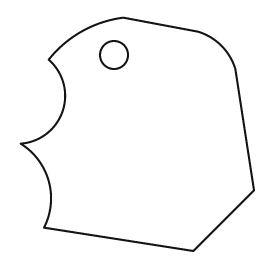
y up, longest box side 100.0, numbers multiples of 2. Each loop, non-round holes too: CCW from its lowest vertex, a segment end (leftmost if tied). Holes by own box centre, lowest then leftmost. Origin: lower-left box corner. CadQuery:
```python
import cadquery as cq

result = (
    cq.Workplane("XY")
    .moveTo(74.0, 0.0)
    .lineTo(100.0, 26.0)
    .lineTo(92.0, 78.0)
    .threePointArc((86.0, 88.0), (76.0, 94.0))
    .lineTo(44.0, 100.0)
    .threePointArc((26.0, 94.0), (12.0, 82.0))
    .threePointArc((18.0, 60.0), (0.0, 46.0))
    .threePointArc((12.0, 30.0), (10.0, 10.0))
    .close()
    .moveTo(40.0, 84.0)
    .circle(6.0)
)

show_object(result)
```